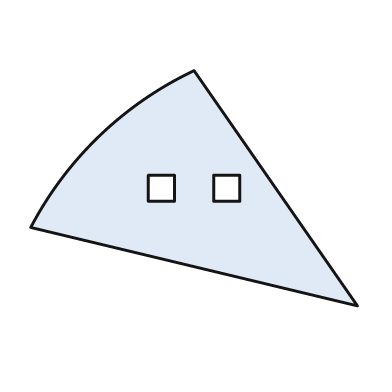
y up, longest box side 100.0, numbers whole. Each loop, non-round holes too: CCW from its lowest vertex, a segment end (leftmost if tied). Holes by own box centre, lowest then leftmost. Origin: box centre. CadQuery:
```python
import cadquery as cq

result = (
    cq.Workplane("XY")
    .moveTo(50.0, -36.0)
    .lineTo(0.0, 36.0)
    .threePointArc((-29.0, 16.0), (-50.0, -12.0))
    .close()
    .moveTo(-14.0, -4.0)
    .lineTo(-6.0, -4.0)
    .lineTo(-6.0, 4.0)
    .lineTo(-14.0, 4.0)
    .close()
    .moveTo(6.0, -4.0)
    .lineTo(14.0, -4.0)
    .lineTo(14.0, 4.0)
    .lineTo(6.0, 4.0)
    .close()
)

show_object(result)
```